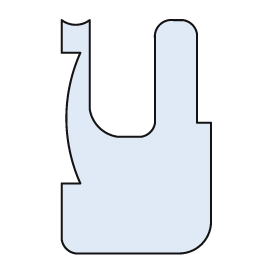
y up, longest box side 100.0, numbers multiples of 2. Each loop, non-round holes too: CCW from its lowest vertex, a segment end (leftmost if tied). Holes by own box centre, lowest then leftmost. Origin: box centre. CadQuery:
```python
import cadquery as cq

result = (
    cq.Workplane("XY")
    .moveTo(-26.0, -50.0)
    .lineTo(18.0, -50.0)
    .threePointArc((28.0, -46.0), (32.0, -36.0))
    .lineTo(32.0, 6.0)
    .lineTo(26.0, 6.0)
    .lineTo(26.0, 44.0)
    .threePointArc((24.0, 48.0), (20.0, 50.0))
    .lineTo(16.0, 50.0)
    .threePointArc((10.0, 48.0), (8.0, 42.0))
    .lineTo(8.0, 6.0)
    .threePointArc((6.0, 2.0), (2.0, 0.0))
    .lineTo(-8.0, 0.0)
    .threePointArc((-16.0, 4.0), (-20.0, 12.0))
    .lineTo(-20.0, 50.0)
    .threePointArc((-26.0, 48.0), (-32.0, 50.0))
    .lineTo(-32.0, 36.0)
    .lineTo(-24.0, 36.0)
    .threePointArc((-30.0, 8.0), (-24.0, -20.0))
    .lineTo(-32.0, -20.0)
    .lineTo(-32.0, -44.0)
    .threePointArc((-30.0, -48.0), (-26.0, -50.0))
    .close()
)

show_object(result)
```